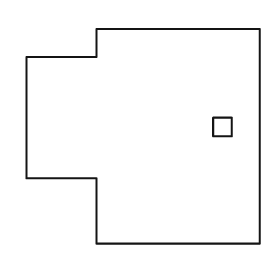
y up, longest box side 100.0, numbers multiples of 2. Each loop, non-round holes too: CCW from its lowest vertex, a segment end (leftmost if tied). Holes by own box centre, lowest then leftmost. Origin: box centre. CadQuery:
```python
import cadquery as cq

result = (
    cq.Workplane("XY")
    .moveTo(-20.0, -46.0)
    .lineTo(50.0, -46.0)
    .lineTo(50.0, 46.0)
    .lineTo(-20.0, 46.0)
    .lineTo(-20.0, 34.0)
    .lineTo(-50.0, 34.0)
    .lineTo(-50.0, -18.0)
    .lineTo(-20.0, -18.0)
    .close()
    .moveTo(30.0, 0.0)
    .lineTo(38.0, 0.0)
    .lineTo(38.0, 8.0)
    .lineTo(30.0, 8.0)
    .close()
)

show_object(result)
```